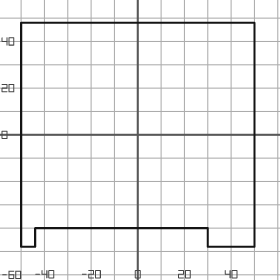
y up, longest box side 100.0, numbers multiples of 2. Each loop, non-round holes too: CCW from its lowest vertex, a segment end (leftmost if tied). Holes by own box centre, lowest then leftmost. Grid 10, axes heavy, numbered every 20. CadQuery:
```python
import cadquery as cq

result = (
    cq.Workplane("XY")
    .moveTo(-50.0, -48.0)
    .lineTo(-44.0, -48.0)
    .lineTo(-44.0, -40.0)
    .lineTo(30.0, -40.0)
    .lineTo(30.0, -48.0)
    .lineTo(50.0, -48.0)
    .lineTo(50.0, 48.0)
    .lineTo(-50.0, 48.0)
    .close()
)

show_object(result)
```